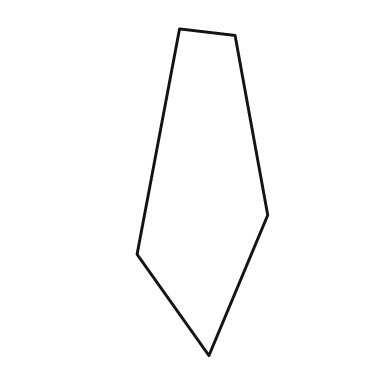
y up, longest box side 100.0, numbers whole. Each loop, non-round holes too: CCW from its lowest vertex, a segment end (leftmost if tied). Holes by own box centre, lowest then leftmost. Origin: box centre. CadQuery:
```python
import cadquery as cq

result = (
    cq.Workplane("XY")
    .moveTo(2.0, -50.0)
    .lineTo(20.0, -7.0)
    .lineTo(10.0, 48.0)
    .lineTo(-7.0, 50.0)
    .lineTo(-20.0, -19.0)
    .close()
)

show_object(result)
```